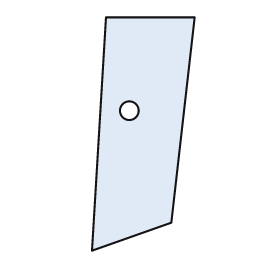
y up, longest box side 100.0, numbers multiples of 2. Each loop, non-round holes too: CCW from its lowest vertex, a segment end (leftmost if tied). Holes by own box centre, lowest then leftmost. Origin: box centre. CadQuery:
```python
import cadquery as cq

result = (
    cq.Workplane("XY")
    .moveTo(-22.0, -50.0)
    .lineTo(12.0, -38.0)
    .lineTo(22.0, 50.0)
    .lineTo(-16.0, 50.0)
    .close()
    .moveTo(-6.0, 10.0)
    .circle(4.0)
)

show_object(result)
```